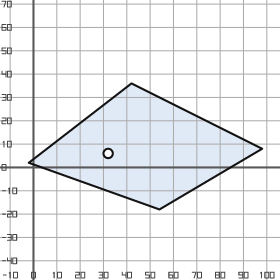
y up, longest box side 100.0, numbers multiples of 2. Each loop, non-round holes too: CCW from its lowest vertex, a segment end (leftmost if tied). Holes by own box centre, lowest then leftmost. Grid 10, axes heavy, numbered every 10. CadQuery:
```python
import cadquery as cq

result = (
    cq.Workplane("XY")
    .moveTo(54.0, -18.0)
    .lineTo(98.0, 8.0)
    .lineTo(42.0, 36.0)
    .lineTo(-2.0, 2.0)
    .close()
    .moveTo(32.0, 6.0)
    .circle(2.0)
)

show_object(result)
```